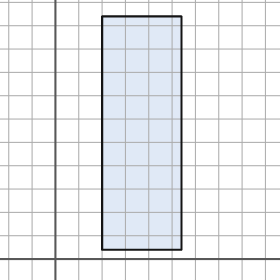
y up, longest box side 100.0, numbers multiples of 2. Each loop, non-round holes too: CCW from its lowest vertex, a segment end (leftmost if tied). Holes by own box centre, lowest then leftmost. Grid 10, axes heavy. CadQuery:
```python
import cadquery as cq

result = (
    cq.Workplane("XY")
    .moveTo(20.0, 4.0)
    .lineTo(54.0, 4.0)
    .lineTo(54.0, 104.0)
    .lineTo(20.0, 104.0)
    .close()
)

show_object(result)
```